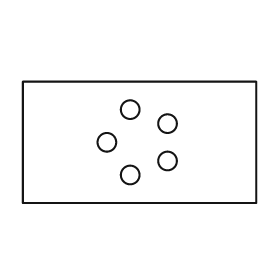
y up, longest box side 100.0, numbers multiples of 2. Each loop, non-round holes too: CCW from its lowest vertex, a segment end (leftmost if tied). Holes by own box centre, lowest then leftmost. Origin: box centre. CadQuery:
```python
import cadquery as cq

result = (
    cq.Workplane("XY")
    .moveTo(-50.0, -26.0)
    .lineTo(50.0, -26.0)
    .lineTo(50.0, 26.0)
    .lineTo(-50.0, 26.0)
    .close()
    .moveTo(-4.0, -14.0)
    .circle(4.0)
    .moveTo(12.0, -8.0)
    .circle(4.0)
    .moveTo(-14.0, 0.0)
    .circle(4.0)
    .moveTo(12.0, 8.0)
    .circle(4.0)
    .moveTo(-4.0, 14.0)
    .circle(4.0)
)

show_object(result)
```